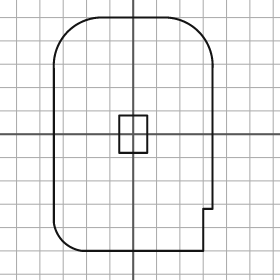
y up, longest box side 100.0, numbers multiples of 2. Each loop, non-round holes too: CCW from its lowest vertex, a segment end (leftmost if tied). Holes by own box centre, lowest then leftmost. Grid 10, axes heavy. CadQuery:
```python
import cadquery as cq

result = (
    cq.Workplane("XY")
    .moveTo(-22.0, -50.0)
    .lineTo(30.0, -50.0)
    .lineTo(30.0, -32.0)
    .lineTo(34.0, -32.0)
    .lineTo(34.0, 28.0)
    .threePointArc((28.0, 44.0), (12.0, 50.0))
    .lineTo(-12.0, 50.0)
    .threePointArc((-28.0, 44.0), (-34.0, 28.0))
    .lineTo(-34.0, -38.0)
    .threePointArc((-30.0, -46.0), (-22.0, -50.0))
    .close()
    .moveTo(-6.0, -8.0)
    .lineTo(6.0, -8.0)
    .lineTo(6.0, 8.0)
    .lineTo(-6.0, 8.0)
    .close()
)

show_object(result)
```